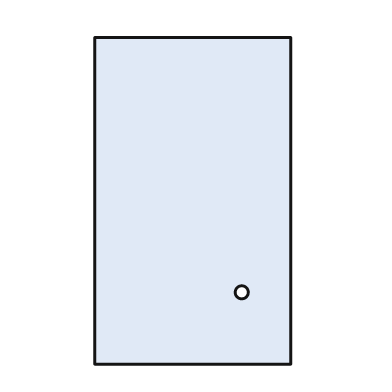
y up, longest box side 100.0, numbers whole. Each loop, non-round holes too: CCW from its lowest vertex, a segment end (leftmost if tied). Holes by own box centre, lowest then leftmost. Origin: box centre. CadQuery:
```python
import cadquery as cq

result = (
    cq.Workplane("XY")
    .moveTo(-30.0, -50.0)
    .lineTo(30.0, -50.0)
    .lineTo(30.0, 50.0)
    .lineTo(-30.0, 50.0)
    .close()
    .moveTo(15.0, -28.0)
    .circle(2.0)
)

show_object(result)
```